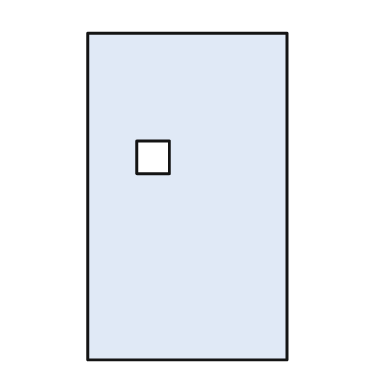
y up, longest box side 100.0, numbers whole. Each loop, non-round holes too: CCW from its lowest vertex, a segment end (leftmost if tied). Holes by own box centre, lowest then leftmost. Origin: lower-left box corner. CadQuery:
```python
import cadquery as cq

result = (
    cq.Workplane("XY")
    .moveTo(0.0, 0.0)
    .lineTo(61.0, 0.0)
    .lineTo(61.0, 100.0)
    .lineTo(0.0, 100.0)
    .close()
    .moveTo(15.0, 57.0)
    .lineTo(25.0, 57.0)
    .lineTo(25.0, 67.0)
    .lineTo(15.0, 67.0)
    .close()
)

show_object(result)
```